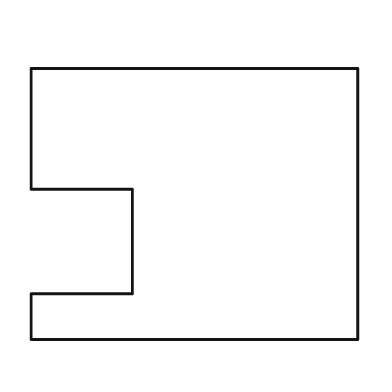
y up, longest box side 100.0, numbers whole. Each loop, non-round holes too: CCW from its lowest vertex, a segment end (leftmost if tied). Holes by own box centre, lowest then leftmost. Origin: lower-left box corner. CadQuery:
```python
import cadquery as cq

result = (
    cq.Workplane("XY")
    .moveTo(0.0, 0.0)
    .lineTo(100.0, 0.0)
    .lineTo(100.0, 83.0)
    .lineTo(0.0, 83.0)
    .lineTo(0.0, 46.0)
    .lineTo(31.0, 46.0)
    .lineTo(31.0, 14.0)
    .lineTo(0.0, 14.0)
    .close()
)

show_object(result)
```